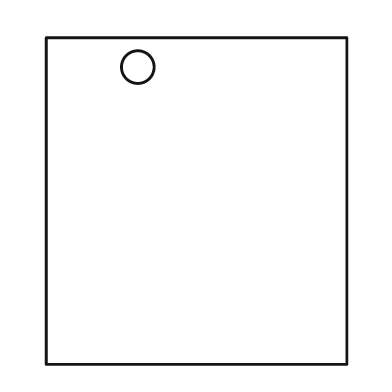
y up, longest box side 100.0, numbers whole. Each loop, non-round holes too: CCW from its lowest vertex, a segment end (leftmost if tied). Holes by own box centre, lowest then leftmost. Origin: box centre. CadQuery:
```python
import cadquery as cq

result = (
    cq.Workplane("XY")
    .moveTo(-46.0, -50.0)
    .lineTo(46.0, -50.0)
    .lineTo(46.0, 50.0)
    .lineTo(-46.0, 50.0)
    .close()
    .moveTo(-18.0, 41.0)
    .circle(5.0)
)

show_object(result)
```